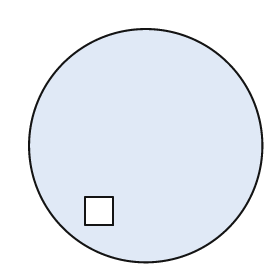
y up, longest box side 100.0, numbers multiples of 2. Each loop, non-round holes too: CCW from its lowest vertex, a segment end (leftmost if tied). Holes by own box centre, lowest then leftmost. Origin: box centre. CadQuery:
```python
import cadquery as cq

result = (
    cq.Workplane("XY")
    .moveTo(0.0, 0.0)
    .circle(50.0)
    .moveTo(-26.0, -34.0)
    .lineTo(-14.0, -34.0)
    .lineTo(-14.0, -22.0)
    .lineTo(-26.0, -22.0)
    .close()
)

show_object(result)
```